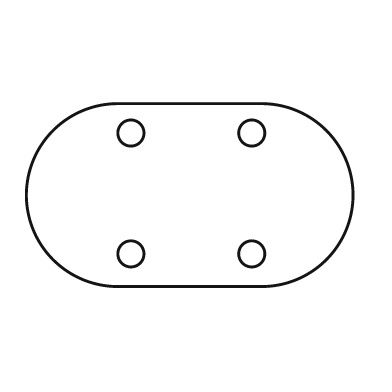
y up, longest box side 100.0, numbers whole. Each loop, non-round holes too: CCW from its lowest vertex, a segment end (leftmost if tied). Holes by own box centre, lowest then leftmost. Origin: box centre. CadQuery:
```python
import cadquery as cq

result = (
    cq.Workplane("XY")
    .moveTo(-22.0, -28.0)
    .lineTo(22.0, -28.0)
    .threePointArc((50.0, 0.0), (22.0, 28.0))
    .lineTo(-22.0, 28.0)
    .threePointArc((-50.0, 0.0), (-22.0, -28.0))
    .close()
    .moveTo(-18.0, -18.0)
    .circle(4.0)
    .moveTo(19.0, -18.0)
    .circle(4.0)
    .moveTo(-18.0, 19.0)
    .circle(4.0)
    .moveTo(19.0, 19.0)
    .circle(4.0)
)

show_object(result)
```